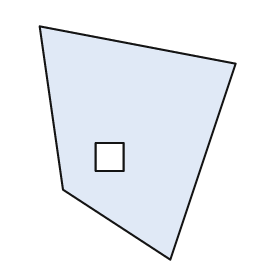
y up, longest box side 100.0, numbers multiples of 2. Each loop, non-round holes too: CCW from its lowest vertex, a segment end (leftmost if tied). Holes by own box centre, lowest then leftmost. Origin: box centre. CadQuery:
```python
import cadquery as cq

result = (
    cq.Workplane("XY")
    .moveTo(14.0, -50.0)
    .lineTo(42.0, 34.0)
    .lineTo(-42.0, 50.0)
    .lineTo(-32.0, -20.0)
    .close()
    .moveTo(-18.0, -12.0)
    .lineTo(-6.0, -12.0)
    .lineTo(-6.0, 0.0)
    .lineTo(-18.0, 0.0)
    .close()
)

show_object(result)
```